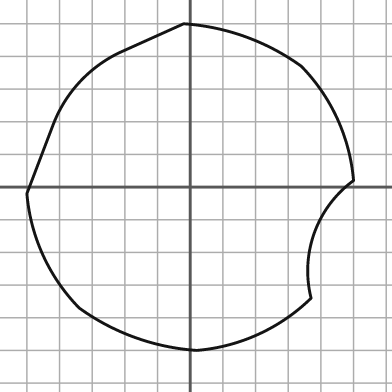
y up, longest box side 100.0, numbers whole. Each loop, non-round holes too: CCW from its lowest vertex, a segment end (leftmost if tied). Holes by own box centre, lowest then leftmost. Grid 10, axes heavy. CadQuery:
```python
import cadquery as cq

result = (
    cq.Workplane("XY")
    .moveTo(2.0, -50.0)
    .threePointArc((21.0, -45.0), (37.0, -34.0))
    .threePointArc((38.0, -14.0), (50.0, 2.0))
    .threePointArc((45.0, 21.0), (34.0, 37.0))
    .threePointArc((17.0, 46.0), (-2.0, 50.0))
    .lineTo(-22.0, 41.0)
    .threePointArc((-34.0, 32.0), (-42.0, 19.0))
    .lineTo(-50.0, -2.0)
    .threePointArc((-45.0, -21.0), (-34.0, -37.0))
    .threePointArc((-17.0, -46.0), (2.0, -50.0))
    .close()
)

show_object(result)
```